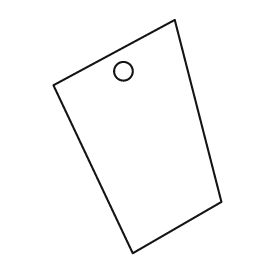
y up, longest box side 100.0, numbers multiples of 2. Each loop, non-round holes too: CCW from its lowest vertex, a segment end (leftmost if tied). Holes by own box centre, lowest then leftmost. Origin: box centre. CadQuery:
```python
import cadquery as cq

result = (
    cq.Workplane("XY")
    .moveTo(-2.0, -50.0)
    .lineTo(36.0, -28.0)
    .lineTo(16.0, 50.0)
    .lineTo(-36.0, 22.0)
    .close()
    .moveTo(-6.0, 28.0)
    .circle(4.0)
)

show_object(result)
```